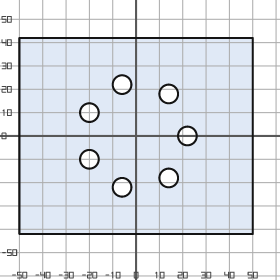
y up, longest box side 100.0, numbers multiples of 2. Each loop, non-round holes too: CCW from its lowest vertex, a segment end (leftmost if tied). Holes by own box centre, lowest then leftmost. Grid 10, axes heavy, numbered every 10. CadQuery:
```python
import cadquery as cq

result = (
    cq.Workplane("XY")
    .moveTo(-50.0, -42.0)
    .lineTo(50.0, -42.0)
    .lineTo(50.0, 42.0)
    .lineTo(-50.0, 42.0)
    .close()
    .moveTo(-6.0, -22.0)
    .circle(4.0)
    .moveTo(14.0, -18.0)
    .circle(4.0)
    .moveTo(-20.0, -10.0)
    .circle(4.0)
    .moveTo(22.0, 0.0)
    .circle(4.0)
    .moveTo(-20.0, 10.0)
    .circle(4.0)
    .moveTo(14.0, 18.0)
    .circle(4.0)
    .moveTo(-6.0, 22.0)
    .circle(4.0)
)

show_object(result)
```